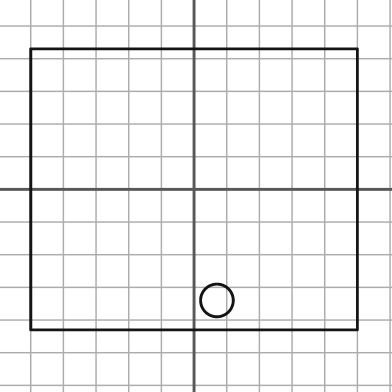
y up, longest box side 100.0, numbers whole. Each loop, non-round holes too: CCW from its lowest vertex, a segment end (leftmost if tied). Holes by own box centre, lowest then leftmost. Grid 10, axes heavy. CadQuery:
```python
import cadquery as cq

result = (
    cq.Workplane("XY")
    .moveTo(-50.0, -43.0)
    .lineTo(50.0, -43.0)
    .lineTo(50.0, 43.0)
    .lineTo(-50.0, 43.0)
    .close()
    .moveTo(7.0, -34.0)
    .circle(5.0)
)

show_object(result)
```